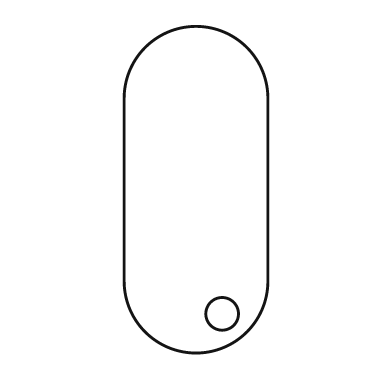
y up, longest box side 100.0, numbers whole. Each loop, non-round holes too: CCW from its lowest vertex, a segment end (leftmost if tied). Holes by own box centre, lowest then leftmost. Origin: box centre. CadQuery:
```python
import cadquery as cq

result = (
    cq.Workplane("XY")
    .moveTo(-22.0, -28.0)
    .threePointArc((0.0, -50.0), (22.0, -28.0))
    .lineTo(22.0, 28.0)
    .threePointArc((0.0, 50.0), (-22.0, 28.0))
    .close()
    .moveTo(8.0, -38.0)
    .circle(5.0)
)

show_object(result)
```